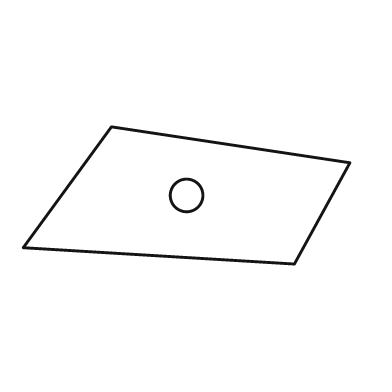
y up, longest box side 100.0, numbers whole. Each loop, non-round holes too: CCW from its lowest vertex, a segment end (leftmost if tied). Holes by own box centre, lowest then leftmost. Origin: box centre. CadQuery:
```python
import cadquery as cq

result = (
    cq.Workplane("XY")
    .moveTo(33.0, -21.0)
    .lineTo(50.0, 10.0)
    .lineTo(-23.0, 21.0)
    .lineTo(-50.0, -16.0)
    .close()
    .moveTo(0.0, 0.0)
    .circle(5.0)
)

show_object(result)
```